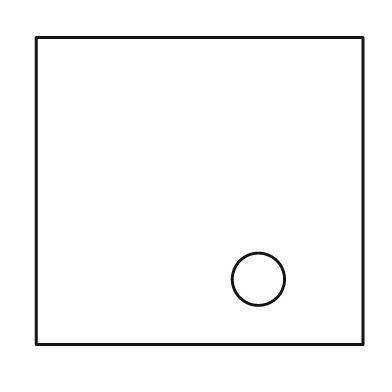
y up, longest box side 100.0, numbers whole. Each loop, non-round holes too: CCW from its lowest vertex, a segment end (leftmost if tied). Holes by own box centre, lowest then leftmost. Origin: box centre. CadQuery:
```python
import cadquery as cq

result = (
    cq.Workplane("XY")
    .moveTo(-50.0, -47.0)
    .lineTo(50.0, -47.0)
    .lineTo(50.0, 47.0)
    .lineTo(-50.0, 47.0)
    .close()
    .moveTo(18.0, -27.0)
    .circle(8.0)
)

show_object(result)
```